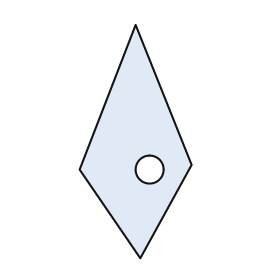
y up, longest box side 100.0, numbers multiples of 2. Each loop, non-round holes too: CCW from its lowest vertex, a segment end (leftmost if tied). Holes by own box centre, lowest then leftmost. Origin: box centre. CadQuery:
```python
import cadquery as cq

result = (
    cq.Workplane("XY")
    .moveTo(2.0, -50.0)
    .lineTo(24.0, -10.0)
    .lineTo(0.0, 50.0)
    .lineTo(-24.0, -12.0)
    .close()
    .moveTo(6.0, -12.0)
    .circle(6.0)
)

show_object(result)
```